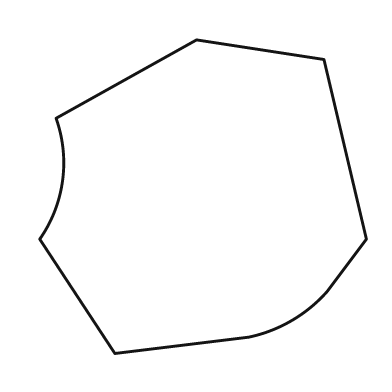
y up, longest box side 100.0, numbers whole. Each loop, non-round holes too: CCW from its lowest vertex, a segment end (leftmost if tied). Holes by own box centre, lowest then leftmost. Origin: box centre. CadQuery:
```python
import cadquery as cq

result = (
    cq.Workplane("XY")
    .moveTo(-27.0, -48.0)
    .lineTo(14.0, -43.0)
    .threePointArc((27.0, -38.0), (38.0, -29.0))
    .lineTo(50.0, -13.0)
    .lineTo(37.0, 42.0)
    .lineTo(-2.0, 48.0)
    .lineTo(-45.0, 24.0)
    .threePointArc((-43.0, 5.0), (-50.0, -13.0))
    .close()
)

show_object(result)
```